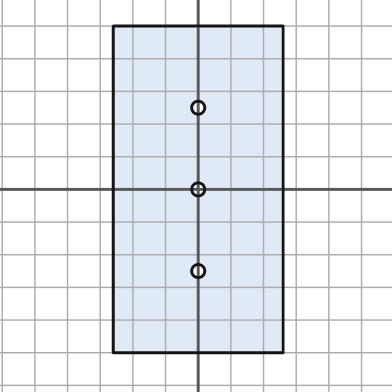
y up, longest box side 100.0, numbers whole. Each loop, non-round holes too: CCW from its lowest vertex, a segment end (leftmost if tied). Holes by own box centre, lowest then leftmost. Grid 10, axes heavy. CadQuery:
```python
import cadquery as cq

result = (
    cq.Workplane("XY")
    .moveTo(-26.0, -50.0)
    .lineTo(26.0, -50.0)
    .lineTo(26.0, 50.0)
    .lineTo(-26.0, 50.0)
    .close()
    .moveTo(0.0, -25.0)
    .circle(2.0)
    .moveTo(0.0, 0.0)
    .circle(2.0)
    .moveTo(0.0, 25.0)
    .circle(2.0)
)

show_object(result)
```